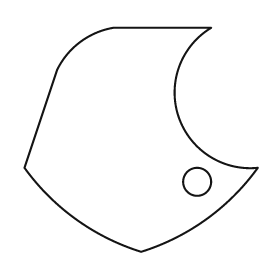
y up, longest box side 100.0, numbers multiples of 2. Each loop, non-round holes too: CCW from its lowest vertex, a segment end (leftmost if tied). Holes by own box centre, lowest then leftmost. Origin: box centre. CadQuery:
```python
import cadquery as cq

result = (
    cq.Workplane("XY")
    .moveTo(0.0, -48.0)
    .threePointArc((28.0, -34.0), (50.0, -12.0))
    .threePointArc((16.0, 10.0), (30.0, 48.0))
    .lineTo(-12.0, 48.0)
    .threePointArc((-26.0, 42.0), (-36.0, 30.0))
    .lineTo(-50.0, -12.0)
    .threePointArc((-28.0, -34.0), (0.0, -48.0))
    .close()
    .moveTo(24.0, -18.0)
    .circle(6.0)
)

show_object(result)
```